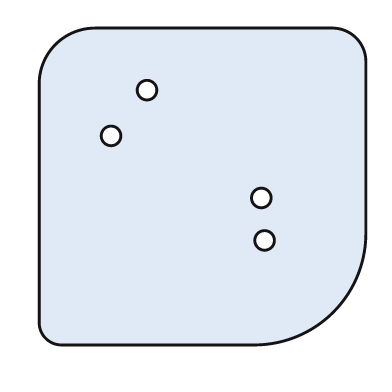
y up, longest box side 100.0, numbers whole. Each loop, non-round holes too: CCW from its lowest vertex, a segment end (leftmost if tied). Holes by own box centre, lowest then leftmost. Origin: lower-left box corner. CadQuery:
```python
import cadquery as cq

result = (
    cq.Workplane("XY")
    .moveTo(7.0, 0.0)
    .lineTo(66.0, 0.0)
    .threePointArc((90.0, 10.0), (100.0, 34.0))
    .lineTo(100.0, 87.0)
    .threePointArc((97.0, 94.0), (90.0, 97.0))
    .lineTo(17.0, 97.0)
    .threePointArc((5.0, 92.0), (0.0, 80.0))
    .lineTo(0.0, 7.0)
    .threePointArc((2.0, 2.0), (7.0, 0.0))
    .close()
    .moveTo(69.0, 32.0)
    .circle(3.0)
    .moveTo(68.0, 45.0)
    .circle(3.0)
    .moveTo(22.0, 64.0)
    .circle(3.0)
    .moveTo(33.0, 78.0)
    .circle(3.0)
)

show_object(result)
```